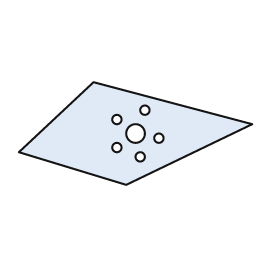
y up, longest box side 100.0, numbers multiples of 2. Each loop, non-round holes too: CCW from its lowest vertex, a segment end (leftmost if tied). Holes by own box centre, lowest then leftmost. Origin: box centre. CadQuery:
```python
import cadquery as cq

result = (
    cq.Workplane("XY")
    .moveTo(-4.0, -22.0)
    .lineTo(50.0, 4.0)
    .lineTo(-18.0, 22.0)
    .lineTo(-50.0, -8.0)
    .close()
    .moveTo(2.0, -10.0)
    .circle(2.0)
    .moveTo(-8.0, -6.0)
    .circle(2.0)
    .moveTo(10.0, -2.0)
    .circle(2.0)
    .moveTo(0.0, 0.0)
    .circle(4.0)
    .moveTo(-8.0, 6.0)
    .circle(2.0)
    .moveTo(4.0, 10.0)
    .circle(2.0)
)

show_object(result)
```